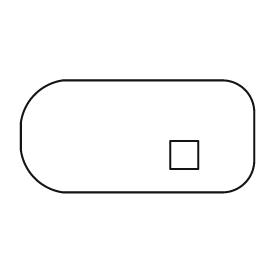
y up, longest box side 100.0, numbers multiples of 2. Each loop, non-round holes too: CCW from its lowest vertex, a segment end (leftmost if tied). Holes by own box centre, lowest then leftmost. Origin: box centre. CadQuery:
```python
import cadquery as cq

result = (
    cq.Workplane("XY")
    .moveTo(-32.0, -24.0)
    .lineTo(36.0, -24.0)
    .threePointArc((46.0, -20.0), (50.0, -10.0))
    .lineTo(50.0, 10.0)
    .threePointArc((46.0, 20.0), (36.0, 24.0))
    .lineTo(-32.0, 24.0)
    .threePointArc((-44.0, 18.0), (-50.0, 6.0))
    .lineTo(-50.0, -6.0)
    .threePointArc((-44.0, -18.0), (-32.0, -24.0))
    .close()
    .moveTo(14.0, -14.0)
    .lineTo(26.0, -14.0)
    .lineTo(26.0, -2.0)
    .lineTo(14.0, -2.0)
    .close()
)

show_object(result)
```